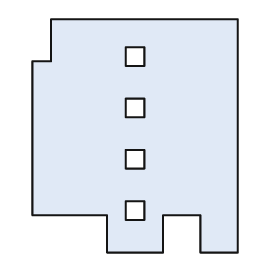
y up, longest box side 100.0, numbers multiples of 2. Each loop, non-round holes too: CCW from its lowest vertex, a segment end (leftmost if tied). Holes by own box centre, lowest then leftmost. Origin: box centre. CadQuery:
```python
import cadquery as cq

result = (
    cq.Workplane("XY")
    .moveTo(-12.0, -50.0)
    .lineTo(12.0, -50.0)
    .lineTo(12.0, -34.0)
    .lineTo(28.0, -34.0)
    .lineTo(28.0, -50.0)
    .lineTo(44.0, -50.0)
    .lineTo(44.0, 50.0)
    .lineTo(-36.0, 50.0)
    .lineTo(-36.0, 32.0)
    .lineTo(-44.0, 32.0)
    .lineTo(-44.0, -34.0)
    .lineTo(-12.0, -34.0)
    .close()
    .moveTo(-4.0, -36.0)
    .lineTo(4.0, -36.0)
    .lineTo(4.0, -28.0)
    .lineTo(-4.0, -28.0)
    .close()
    .moveTo(-4.0, -14.0)
    .lineTo(4.0, -14.0)
    .lineTo(4.0, -6.0)
    .lineTo(-4.0, -6.0)
    .close()
    .moveTo(-4.0, 8.0)
    .lineTo(4.0, 8.0)
    .lineTo(4.0, 16.0)
    .lineTo(-4.0, 16.0)
    .close()
    .moveTo(-4.0, 30.0)
    .lineTo(4.0, 30.0)
    .lineTo(4.0, 38.0)
    .lineTo(-4.0, 38.0)
    .close()
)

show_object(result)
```